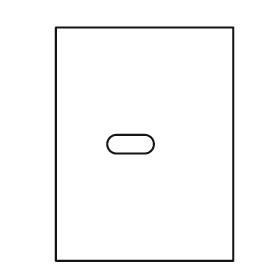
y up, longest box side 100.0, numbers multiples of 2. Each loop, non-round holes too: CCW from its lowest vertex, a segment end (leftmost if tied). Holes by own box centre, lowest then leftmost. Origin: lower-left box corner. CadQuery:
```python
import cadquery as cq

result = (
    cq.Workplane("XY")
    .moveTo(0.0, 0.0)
    .lineTo(76.0, 0.0)
    .lineTo(76.0, 100.0)
    .lineTo(0.0, 100.0)
    .close()
    .moveTo(26.0, 46.0)
    .lineTo(38.0, 46.0)
    .threePointArc((42.0, 50.0), (38.0, 54.0))
    .lineTo(26.0, 54.0)
    .threePointArc((22.0, 50.0), (26.0, 46.0))
    .close()
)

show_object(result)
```